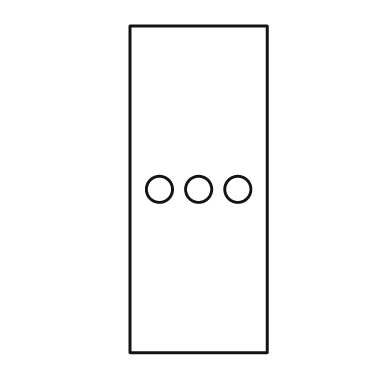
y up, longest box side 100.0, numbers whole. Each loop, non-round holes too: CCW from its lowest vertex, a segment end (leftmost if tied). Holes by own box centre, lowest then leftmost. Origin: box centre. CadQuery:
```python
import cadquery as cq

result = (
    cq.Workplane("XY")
    .moveTo(-21.0, -50.0)
    .lineTo(21.0, -50.0)
    .lineTo(21.0, 50.0)
    .lineTo(-21.0, 50.0)
    .close()
    .moveTo(-12.0, 0.0)
    .circle(4.0)
    .moveTo(0.0, 0.0)
    .circle(4.0)
    .moveTo(12.0, 0.0)
    .circle(4.0)
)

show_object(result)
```